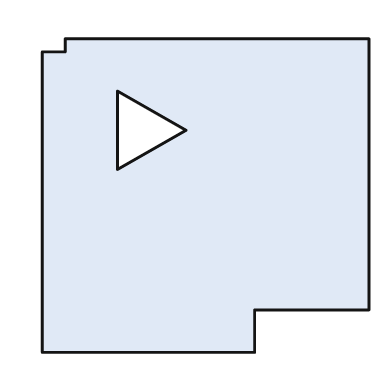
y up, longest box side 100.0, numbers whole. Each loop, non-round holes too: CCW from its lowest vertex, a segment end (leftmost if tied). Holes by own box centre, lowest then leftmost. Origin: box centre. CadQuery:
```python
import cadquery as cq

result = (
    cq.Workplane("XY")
    .moveTo(-50.0, -48.0)
    .lineTo(15.0, -48.0)
    .lineTo(15.0, -35.0)
    .lineTo(50.0, -35.0)
    .lineTo(50.0, 48.0)
    .lineTo(-43.0, 48.0)
    .lineTo(-43.0, 44.0)
    .lineTo(-50.0, 44.0)
    .close()
    .moveTo(-27.0, 8.0)
    .lineTo(-6.0, 20.0)
    .lineTo(-27.0, 32.0)
    .close()
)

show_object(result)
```